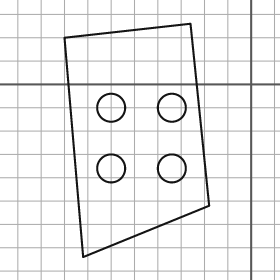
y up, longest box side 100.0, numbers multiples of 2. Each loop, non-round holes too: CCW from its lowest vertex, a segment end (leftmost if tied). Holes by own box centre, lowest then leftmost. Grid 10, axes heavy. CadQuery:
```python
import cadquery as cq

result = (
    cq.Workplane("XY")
    .moveTo(-72.0, -74.0)
    .lineTo(-18.0, -52.0)
    .lineTo(-26.0, 26.0)
    .lineTo(-80.0, 20.0)
    .close()
    .moveTo(-60.0, -36.0)
    .circle(6.0)
    .moveTo(-34.0, -36.0)
    .circle(6.0)
    .moveTo(-60.0, -10.0)
    .circle(6.0)
    .moveTo(-34.0, -10.0)
    .circle(6.0)
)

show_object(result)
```